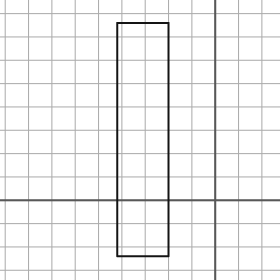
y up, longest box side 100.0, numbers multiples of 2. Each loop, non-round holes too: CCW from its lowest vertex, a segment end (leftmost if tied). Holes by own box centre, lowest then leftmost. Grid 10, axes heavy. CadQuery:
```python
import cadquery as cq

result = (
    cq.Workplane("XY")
    .moveTo(-42.0, -24.0)
    .lineTo(-20.0, -24.0)
    .lineTo(-20.0, 76.0)
    .lineTo(-42.0, 76.0)
    .close()
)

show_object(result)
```